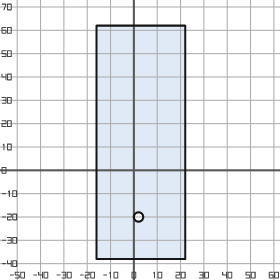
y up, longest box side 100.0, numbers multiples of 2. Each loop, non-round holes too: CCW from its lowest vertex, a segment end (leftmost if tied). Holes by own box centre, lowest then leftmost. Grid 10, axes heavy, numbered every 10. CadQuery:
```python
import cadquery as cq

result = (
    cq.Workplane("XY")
    .moveTo(-16.0, -38.0)
    .lineTo(22.0, -38.0)
    .lineTo(22.0, 62.0)
    .lineTo(-16.0, 62.0)
    .close()
    .moveTo(2.0, -20.0)
    .circle(2.0)
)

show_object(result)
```